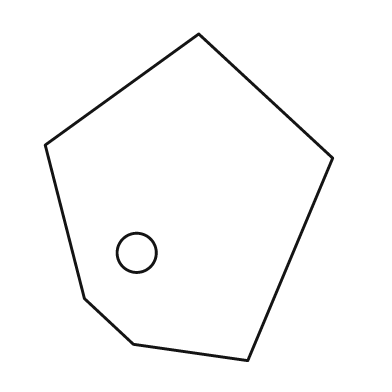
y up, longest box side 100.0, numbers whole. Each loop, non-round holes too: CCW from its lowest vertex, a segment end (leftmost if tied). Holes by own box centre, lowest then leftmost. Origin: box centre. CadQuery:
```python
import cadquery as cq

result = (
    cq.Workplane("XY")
    .moveTo(18.0, -50.0)
    .lineTo(44.0, 12.0)
    .lineTo(3.0, 50.0)
    .lineTo(-44.0, 16.0)
    .lineTo(-32.0, -31.0)
    .lineTo(-17.0, -45.0)
    .close()
    .moveTo(-16.0, -17.0)
    .circle(6.0)
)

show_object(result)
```